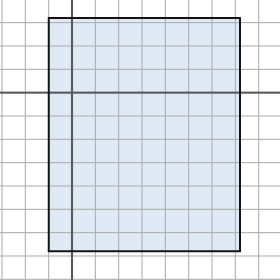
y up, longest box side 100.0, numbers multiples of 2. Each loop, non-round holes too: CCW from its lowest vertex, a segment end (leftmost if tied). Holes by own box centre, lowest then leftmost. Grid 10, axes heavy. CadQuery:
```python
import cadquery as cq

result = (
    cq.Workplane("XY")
    .moveTo(-10.0, -68.0)
    .lineTo(72.0, -68.0)
    .lineTo(72.0, 32.0)
    .lineTo(-10.0, 32.0)
    .close()
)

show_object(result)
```